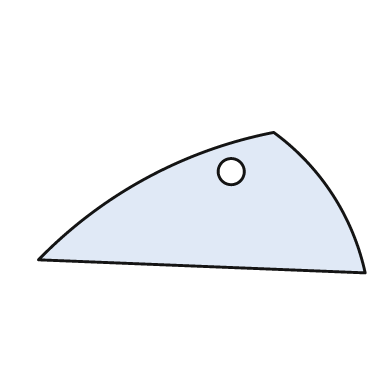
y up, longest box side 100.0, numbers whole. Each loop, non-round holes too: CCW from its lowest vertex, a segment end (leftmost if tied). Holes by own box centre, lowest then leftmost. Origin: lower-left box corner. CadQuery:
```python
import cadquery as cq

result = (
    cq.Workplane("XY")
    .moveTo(100.0, 0.0)
    .threePointArc((90.0, 24.0), (72.0, 43.0))
    .threePointArc((33.0, 29.0), (0.0, 4.0))
    .close()
    .moveTo(59.0, 31.0)
    .circle(4.0)
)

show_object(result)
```